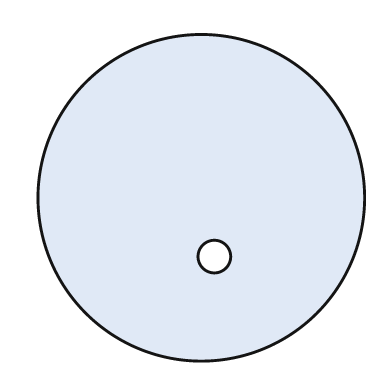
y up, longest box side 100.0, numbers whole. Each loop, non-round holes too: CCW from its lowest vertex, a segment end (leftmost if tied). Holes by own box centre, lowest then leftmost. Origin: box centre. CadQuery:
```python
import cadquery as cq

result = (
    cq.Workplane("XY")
    .moveTo(0.0, 0.0)
    .circle(50.0)
    .moveTo(4.0, -18.0)
    .circle(5.0)
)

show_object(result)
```